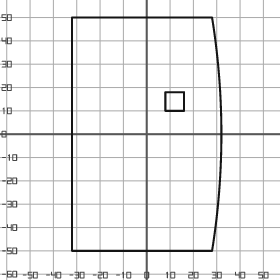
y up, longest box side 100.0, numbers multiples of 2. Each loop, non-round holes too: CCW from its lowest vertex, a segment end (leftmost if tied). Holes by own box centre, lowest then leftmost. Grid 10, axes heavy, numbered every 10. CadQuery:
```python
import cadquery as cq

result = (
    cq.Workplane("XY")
    .moveTo(-32.0, -50.0)
    .lineTo(28.0, -50.0)
    .threePointArc((32.0, 0.0), (28.0, 50.0))
    .lineTo(-32.0, 50.0)
    .close()
    .moveTo(8.0, 10.0)
    .lineTo(16.0, 10.0)
    .lineTo(16.0, 18.0)
    .lineTo(8.0, 18.0)
    .close()
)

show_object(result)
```